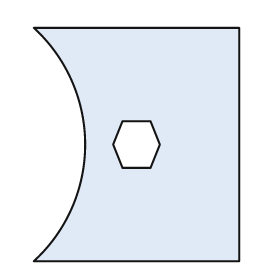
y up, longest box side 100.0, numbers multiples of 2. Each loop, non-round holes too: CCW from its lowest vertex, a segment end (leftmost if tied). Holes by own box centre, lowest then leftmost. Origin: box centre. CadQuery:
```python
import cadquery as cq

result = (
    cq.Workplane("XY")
    .moveTo(-44.0, -50.0)
    .lineTo(44.0, -50.0)
    .lineTo(44.0, 50.0)
    .lineTo(-44.0, 50.0)
    .threePointArc((-22.0, 0.0), (-44.0, -50.0))
    .close()
    .moveTo(-6.0, -10.0)
    .lineTo(6.0, -10.0)
    .lineTo(10.0, 0.0)
    .lineTo(6.0, 10.0)
    .lineTo(-6.0, 10.0)
    .lineTo(-10.0, 0.0)
    .close()
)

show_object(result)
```